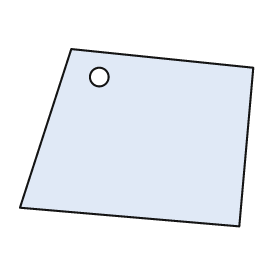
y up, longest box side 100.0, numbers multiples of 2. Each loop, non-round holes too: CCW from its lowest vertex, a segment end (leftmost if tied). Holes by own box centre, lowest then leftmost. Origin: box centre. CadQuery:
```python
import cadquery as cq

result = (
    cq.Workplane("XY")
    .moveTo(44.0, -38.0)
    .lineTo(50.0, 30.0)
    .lineTo(-28.0, 38.0)
    .lineTo(-50.0, -30.0)
    .close()
    .moveTo(-16.0, 26.0)
    .circle(4.0)
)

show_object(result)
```